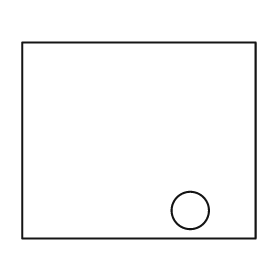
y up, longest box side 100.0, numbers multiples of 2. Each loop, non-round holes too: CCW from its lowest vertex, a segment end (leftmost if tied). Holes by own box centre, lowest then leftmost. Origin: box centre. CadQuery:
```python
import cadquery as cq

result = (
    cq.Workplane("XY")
    .moveTo(-50.0, -42.0)
    .lineTo(50.0, -42.0)
    .lineTo(50.0, 42.0)
    .lineTo(-50.0, 42.0)
    .close()
    .moveTo(22.0, -30.0)
    .circle(8.0)
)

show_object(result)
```